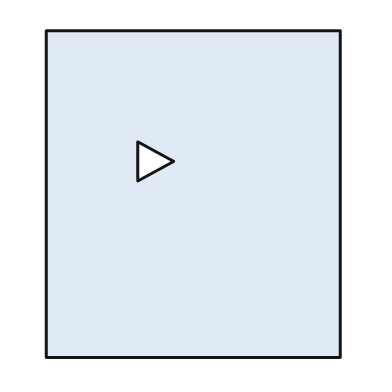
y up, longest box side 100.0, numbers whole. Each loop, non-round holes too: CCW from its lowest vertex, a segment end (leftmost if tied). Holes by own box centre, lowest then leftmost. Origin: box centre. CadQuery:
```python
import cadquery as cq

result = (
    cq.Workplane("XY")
    .moveTo(-45.0, -50.0)
    .lineTo(45.0, -50.0)
    .lineTo(45.0, 50.0)
    .lineTo(-45.0, 50.0)
    .close()
    .moveTo(-17.0, 4.0)
    .lineTo(-6.0, 10.0)
    .lineTo(-17.0, 16.0)
    .close()
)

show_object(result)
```